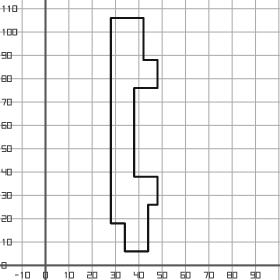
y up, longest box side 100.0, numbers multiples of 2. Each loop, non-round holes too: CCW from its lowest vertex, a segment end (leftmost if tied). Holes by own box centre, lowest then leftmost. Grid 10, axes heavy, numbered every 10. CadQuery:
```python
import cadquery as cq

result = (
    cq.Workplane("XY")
    .moveTo(34.0, 6.0)
    .lineTo(44.0, 6.0)
    .lineTo(44.0, 26.0)
    .lineTo(48.0, 26.0)
    .lineTo(48.0, 38.0)
    .lineTo(38.0, 38.0)
    .lineTo(38.0, 76.0)
    .lineTo(48.0, 76.0)
    .lineTo(48.0, 88.0)
    .lineTo(42.0, 88.0)
    .lineTo(42.0, 106.0)
    .lineTo(28.0, 106.0)
    .lineTo(28.0, 18.0)
    .lineTo(34.0, 18.0)
    .close()
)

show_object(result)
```